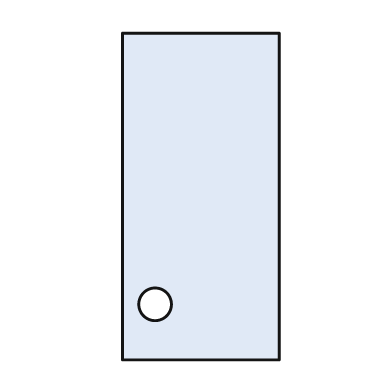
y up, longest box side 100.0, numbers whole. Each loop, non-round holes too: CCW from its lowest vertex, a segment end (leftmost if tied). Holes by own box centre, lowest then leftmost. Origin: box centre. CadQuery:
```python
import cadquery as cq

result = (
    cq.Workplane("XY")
    .moveTo(-24.0, -50.0)
    .lineTo(24.0, -50.0)
    .lineTo(24.0, 50.0)
    .lineTo(-24.0, 50.0)
    .close()
    .moveTo(-14.0, -33.0)
    .circle(5.0)
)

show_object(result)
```